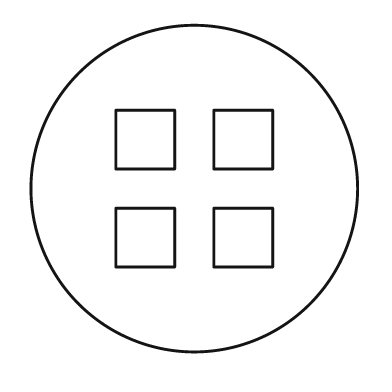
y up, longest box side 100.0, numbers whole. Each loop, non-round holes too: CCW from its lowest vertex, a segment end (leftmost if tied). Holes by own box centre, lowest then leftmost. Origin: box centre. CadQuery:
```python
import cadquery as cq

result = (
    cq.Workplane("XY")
    .moveTo(0.0, 0.0)
    .circle(50.0)
    .moveTo(-24.0, -24.0)
    .lineTo(-6.0, -24.0)
    .lineTo(-6.0, -6.0)
    .lineTo(-24.0, -6.0)
    .close()
    .moveTo(6.0, -24.0)
    .lineTo(24.0, -24.0)
    .lineTo(24.0, -6.0)
    .lineTo(6.0, -6.0)
    .close()
    .moveTo(-24.0, 6.0)
    .lineTo(-6.0, 6.0)
    .lineTo(-6.0, 24.0)
    .lineTo(-24.0, 24.0)
    .close()
    .moveTo(6.0, 6.0)
    .lineTo(24.0, 6.0)
    .lineTo(24.0, 24.0)
    .lineTo(6.0, 24.0)
    .close()
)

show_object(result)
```